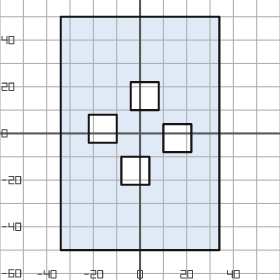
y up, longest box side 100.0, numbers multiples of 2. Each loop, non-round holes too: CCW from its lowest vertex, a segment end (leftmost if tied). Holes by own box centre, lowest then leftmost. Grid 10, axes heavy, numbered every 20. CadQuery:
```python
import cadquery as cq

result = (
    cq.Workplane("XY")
    .moveTo(-34.0, -50.0)
    .lineTo(34.0, -50.0)
    .lineTo(34.0, 50.0)
    .lineTo(-34.0, 50.0)
    .close()
    .moveTo(-8.0, -22.0)
    .lineTo(4.0, -22.0)
    .lineTo(4.0, -10.0)
    .lineTo(-8.0, -10.0)
    .close()
    .moveTo(10.0, -8.0)
    .lineTo(22.0, -8.0)
    .lineTo(22.0, 4.0)
    .lineTo(10.0, 4.0)
    .close()
    .moveTo(-22.0, -4.0)
    .lineTo(-10.0, -4.0)
    .lineTo(-10.0, 8.0)
    .lineTo(-22.0, 8.0)
    .close()
    .moveTo(-4.0, 10.0)
    .lineTo(8.0, 10.0)
    .lineTo(8.0, 22.0)
    .lineTo(-4.0, 22.0)
    .close()
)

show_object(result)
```